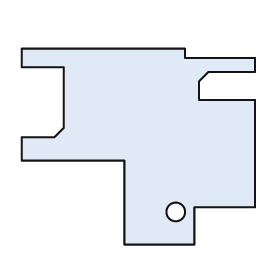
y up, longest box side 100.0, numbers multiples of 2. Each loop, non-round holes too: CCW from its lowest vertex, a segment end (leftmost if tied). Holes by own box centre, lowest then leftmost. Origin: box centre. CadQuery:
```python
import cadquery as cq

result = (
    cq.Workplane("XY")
    .moveTo(-6.0, -42.0)
    .lineTo(24.0, -42.0)
    .lineTo(24.0, -26.0)
    .lineTo(50.0, -26.0)
    .lineTo(50.0, 20.0)
    .lineTo(26.0, 20.0)
    .lineTo(26.0, 28.0)
    .lineTo(30.0, 32.0)
    .lineTo(50.0, 32.0)
    .lineTo(50.0, 38.0)
    .lineTo(20.0, 38.0)
    .lineTo(20.0, 42.0)
    .lineTo(-50.0, 42.0)
    .lineTo(-50.0, 34.0)
    .lineTo(-32.0, 34.0)
    .lineTo(-32.0, 8.0)
    .lineTo(-36.0, 4.0)
    .lineTo(-50.0, 4.0)
    .lineTo(-50.0, -6.0)
    .lineTo(-6.0, -6.0)
    .close()
    .moveTo(16.0, -28.0)
    .circle(4.0)
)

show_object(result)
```